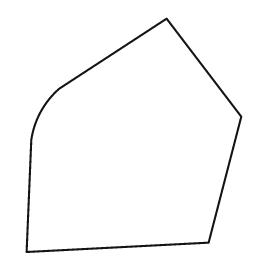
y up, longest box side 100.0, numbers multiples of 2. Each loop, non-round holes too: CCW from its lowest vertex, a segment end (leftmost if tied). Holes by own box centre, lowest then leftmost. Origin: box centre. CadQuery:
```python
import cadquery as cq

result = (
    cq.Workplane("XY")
    .moveTo(-46.0, -50.0)
    .lineTo(32.0, -46.0)
    .lineTo(46.0, 8.0)
    .lineTo(14.0, 50.0)
    .lineTo(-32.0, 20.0)
    .threePointArc((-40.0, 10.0), (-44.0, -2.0))
    .close()
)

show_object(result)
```